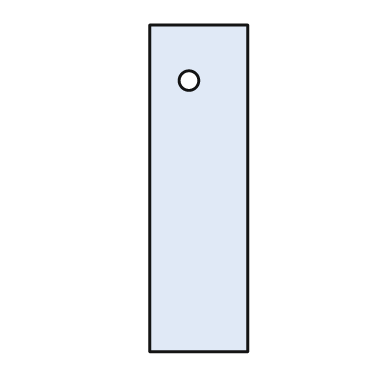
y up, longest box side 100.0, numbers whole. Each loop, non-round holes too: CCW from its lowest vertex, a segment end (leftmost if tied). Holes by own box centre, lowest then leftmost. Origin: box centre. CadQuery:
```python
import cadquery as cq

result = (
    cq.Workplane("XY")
    .moveTo(-15.0, -50.0)
    .lineTo(15.0, -50.0)
    .lineTo(15.0, 50.0)
    .lineTo(-15.0, 50.0)
    .close()
    .moveTo(-3.0, 33.0)
    .circle(3.0)
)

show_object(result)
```